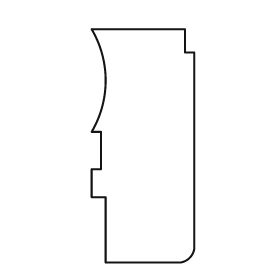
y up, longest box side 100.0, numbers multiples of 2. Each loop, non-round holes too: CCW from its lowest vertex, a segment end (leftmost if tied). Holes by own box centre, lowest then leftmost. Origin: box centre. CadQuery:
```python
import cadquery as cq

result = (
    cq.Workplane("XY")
    .moveTo(-16.0, -50.0)
    .lineTo(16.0, -50.0)
    .threePointArc((20.0, -48.0), (22.0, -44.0))
    .lineTo(22.0, 40.0)
    .lineTo(18.0, 40.0)
    .lineTo(18.0, 50.0)
    .lineTo(-22.0, 50.0)
    .threePointArc((-16.0, 28.0), (-22.0, 6.0))
    .lineTo(-18.0, 6.0)
    .lineTo(-18.0, -10.0)
    .lineTo(-22.0, -10.0)
    .lineTo(-22.0, -22.0)
    .lineTo(-16.0, -22.0)
    .close()
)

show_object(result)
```